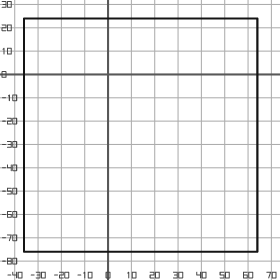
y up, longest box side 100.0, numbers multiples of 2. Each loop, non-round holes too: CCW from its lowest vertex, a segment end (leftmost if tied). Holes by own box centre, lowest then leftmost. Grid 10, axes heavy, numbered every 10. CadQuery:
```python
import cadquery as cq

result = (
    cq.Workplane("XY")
    .moveTo(-36.0, -76.0)
    .lineTo(64.0, -76.0)
    .lineTo(64.0, 24.0)
    .lineTo(-36.0, 24.0)
    .close()
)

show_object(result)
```